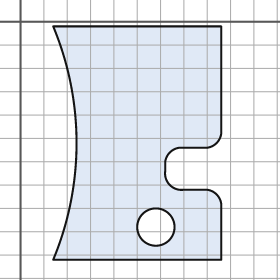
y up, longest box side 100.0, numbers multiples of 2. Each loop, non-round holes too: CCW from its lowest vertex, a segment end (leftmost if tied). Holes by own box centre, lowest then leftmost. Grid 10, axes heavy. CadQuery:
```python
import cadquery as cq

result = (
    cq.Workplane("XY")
    .moveTo(14.0, -102.0)
    .lineTo(86.0, -102.0)
    .lineTo(86.0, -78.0)
    .threePointArc((84.0, -74.0), (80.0, -72.0))
    .lineTo(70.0, -72.0)
    .threePointArc((64.0, -70.0), (62.0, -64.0))
    .lineTo(62.0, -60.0)
    .threePointArc((64.0, -56.0), (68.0, -54.0))
    .lineTo(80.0, -54.0)
    .threePointArc((84.0, -52.0), (86.0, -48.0))
    .lineTo(86.0, -2.0)
    .lineTo(14.0, -2.0)
    .threePointArc((24.0, -52.0), (14.0, -102.0))
    .close()
    .moveTo(58.0, -88.0)
    .circle(8.0)
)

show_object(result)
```